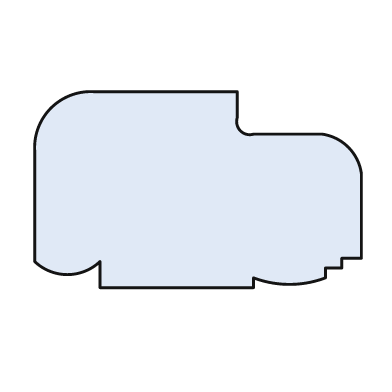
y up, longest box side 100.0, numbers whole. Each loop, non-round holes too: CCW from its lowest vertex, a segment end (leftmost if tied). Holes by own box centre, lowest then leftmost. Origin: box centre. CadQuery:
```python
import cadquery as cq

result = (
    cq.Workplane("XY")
    .moveTo(-30.0, -30.0)
    .lineTo(17.0, -30.0)
    .lineTo(17.0, -27.0)
    .threePointArc((28.0, -29.0), (39.0, -27.0))
    .lineTo(39.0, -24.0)
    .lineTo(44.0, -24.0)
    .lineTo(44.0, -21.0)
    .lineTo(50.0, -21.0)
    .lineTo(50.0, 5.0)
    .threePointArc((46.0, 13.0), (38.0, 17.0))
    .lineTo(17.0, 17.0)
    .threePointArc((13.0, 18.0), (12.0, 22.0))
    .lineTo(12.0, 30.0)
    .lineTo(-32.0, 30.0)
    .threePointArc((-45.0, 25.0), (-50.0, 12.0))
    .lineTo(-50.0, -22.0)
    .threePointArc((-40.0, -26.0), (-30.0, -22.0))
    .close()
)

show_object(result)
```